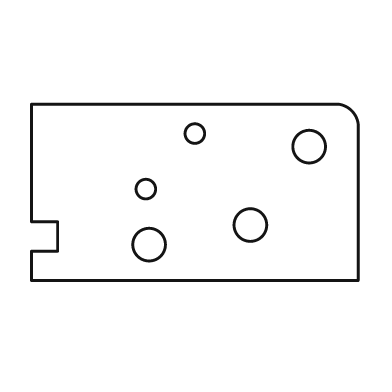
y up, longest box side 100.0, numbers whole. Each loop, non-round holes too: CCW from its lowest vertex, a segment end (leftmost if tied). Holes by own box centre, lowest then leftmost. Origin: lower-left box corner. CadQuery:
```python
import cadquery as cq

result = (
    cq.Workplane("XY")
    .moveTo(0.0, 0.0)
    .lineTo(100.0, 0.0)
    .lineTo(100.0, 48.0)
    .threePointArc((98.0, 52.0), (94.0, 54.0))
    .lineTo(0.0, 54.0)
    .lineTo(0.0, 18.0)
    .lineTo(8.0, 18.0)
    .lineTo(8.0, 9.0)
    .lineTo(0.0, 9.0)
    .close()
    .moveTo(36.0, 11.0)
    .circle(5.0)
    .moveTo(67.0, 17.0)
    .circle(5.0)
    .moveTo(35.0, 28.0)
    .circle(3.0)
    .moveTo(85.0, 41.0)
    .circle(5.0)
    .moveTo(50.0, 45.0)
    .circle(3.0)
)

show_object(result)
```